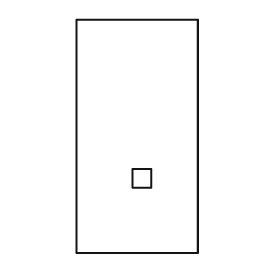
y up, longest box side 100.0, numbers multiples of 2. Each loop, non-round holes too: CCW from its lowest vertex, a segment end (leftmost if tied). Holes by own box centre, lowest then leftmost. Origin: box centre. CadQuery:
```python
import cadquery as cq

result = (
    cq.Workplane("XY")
    .moveTo(-26.0, -50.0)
    .lineTo(26.0, -50.0)
    .lineTo(26.0, 50.0)
    .lineTo(-26.0, 50.0)
    .close()
    .moveTo(-2.0, -22.0)
    .lineTo(6.0, -22.0)
    .lineTo(6.0, -14.0)
    .lineTo(-2.0, -14.0)
    .close()
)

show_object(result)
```